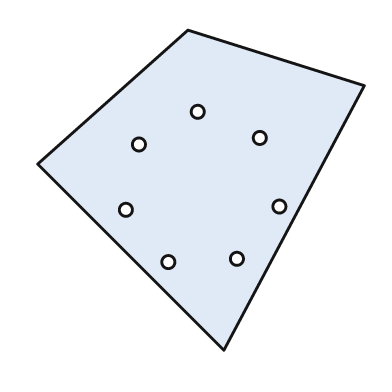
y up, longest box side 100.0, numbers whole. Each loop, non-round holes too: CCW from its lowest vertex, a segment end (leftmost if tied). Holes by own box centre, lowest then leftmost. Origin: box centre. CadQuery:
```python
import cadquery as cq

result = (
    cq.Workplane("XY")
    .moveTo(7.0, -49.0)
    .lineTo(50.0, 32.0)
    .lineTo(-4.0, 49.0)
    .lineTo(-50.0, 8.0)
    .close()
    .moveTo(-10.0, -22.0)
    .circle(2.0)
    .moveTo(11.0, -21.0)
    .circle(2.0)
    .moveTo(-23.0, -6.0)
    .circle(2.0)
    .moveTo(24.0, -5.0)
    .circle(2.0)
    .moveTo(-19.0, 14.0)
    .circle(2.0)
    .moveTo(18.0, 16.0)
    .circle(2.0)
    .moveTo(-1.0, 24.0)
    .circle(2.0)
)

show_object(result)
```